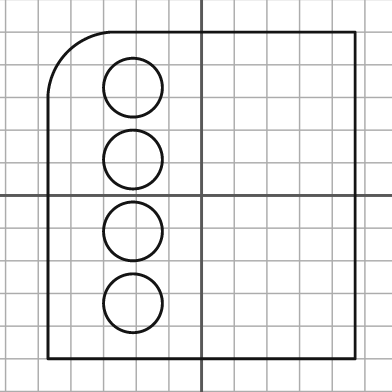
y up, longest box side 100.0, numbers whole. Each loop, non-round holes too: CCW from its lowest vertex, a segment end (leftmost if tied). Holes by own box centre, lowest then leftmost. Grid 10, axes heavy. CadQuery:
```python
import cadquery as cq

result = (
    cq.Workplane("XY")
    .moveTo(-47.0, -50.0)
    .lineTo(47.0, -50.0)
    .lineTo(47.0, 50.0)
    .lineTo(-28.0, 50.0)
    .threePointArc((-41.0, 44.0), (-47.0, 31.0))
    .close()
    .moveTo(-21.0, -33.0)
    .circle(9.0)
    .moveTo(-21.0, -11.0)
    .circle(9.0)
    .moveTo(-21.0, 11.0)
    .circle(9.0)
    .moveTo(-21.0, 33.0)
    .circle(9.0)
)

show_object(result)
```